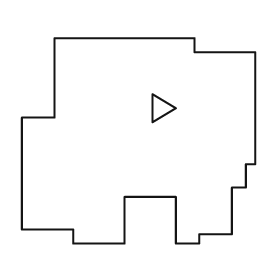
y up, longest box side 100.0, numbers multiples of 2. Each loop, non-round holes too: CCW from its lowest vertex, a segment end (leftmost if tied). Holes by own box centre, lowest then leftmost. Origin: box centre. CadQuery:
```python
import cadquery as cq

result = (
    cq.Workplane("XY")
    .moveTo(-28.0, -44.0)
    .lineTo(-6.0, -44.0)
    .lineTo(-6.0, -24.0)
    .lineTo(16.0, -24.0)
    .lineTo(16.0, -44.0)
    .lineTo(26.0, -44.0)
    .lineTo(26.0, -40.0)
    .lineTo(40.0, -40.0)
    .lineTo(40.0, -20.0)
    .lineTo(46.0, -20.0)
    .lineTo(46.0, -10.0)
    .lineTo(50.0, -10.0)
    .lineTo(50.0, 38.0)
    .lineTo(24.0, 38.0)
    .lineTo(24.0, 44.0)
    .lineTo(-36.0, 44.0)
    .lineTo(-36.0, 10.0)
    .lineTo(-50.0, 10.0)
    .lineTo(-50.0, -38.0)
    .lineTo(-28.0, -38.0)
    .close()
    .moveTo(6.0, 8.0)
    .lineTo(16.0, 14.0)
    .lineTo(6.0, 20.0)
    .close()
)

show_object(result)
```